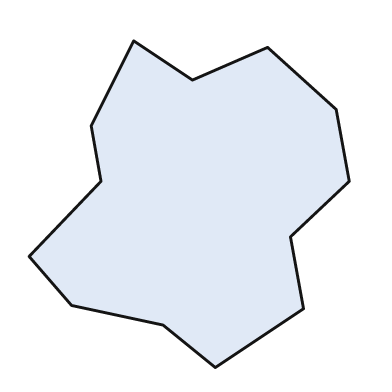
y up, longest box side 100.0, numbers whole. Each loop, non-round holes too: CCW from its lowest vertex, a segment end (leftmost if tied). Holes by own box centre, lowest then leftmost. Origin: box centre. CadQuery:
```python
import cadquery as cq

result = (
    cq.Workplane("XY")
    .moveTo(8.0, -50.0)
    .lineTo(35.0, -32.0)
    .lineTo(31.0, -10.0)
    .lineTo(49.0, 7.0)
    .lineTo(45.0, 29.0)
    .lineTo(24.0, 48.0)
    .lineTo(1.0, 38.0)
    .lineTo(-17.0, 50.0)
    .lineTo(-30.0, 24.0)
    .lineTo(-27.0, 7.0)
    .lineTo(-49.0, -16.0)
    .lineTo(-36.0, -31.0)
    .lineTo(-8.0, -37.0)
    .close()
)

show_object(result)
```